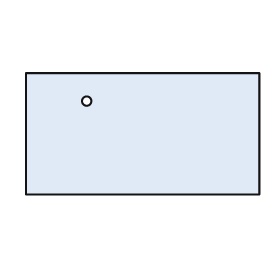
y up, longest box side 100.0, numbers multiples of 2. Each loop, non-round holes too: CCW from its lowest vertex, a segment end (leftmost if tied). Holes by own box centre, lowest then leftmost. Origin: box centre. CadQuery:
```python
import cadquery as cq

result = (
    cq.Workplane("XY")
    .moveTo(-50.0, -26.0)
    .lineTo(50.0, -26.0)
    .lineTo(50.0, 26.0)
    .lineTo(-50.0, 26.0)
    .close()
    .moveTo(-24.0, 14.0)
    .circle(2.0)
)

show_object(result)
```